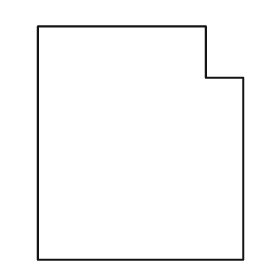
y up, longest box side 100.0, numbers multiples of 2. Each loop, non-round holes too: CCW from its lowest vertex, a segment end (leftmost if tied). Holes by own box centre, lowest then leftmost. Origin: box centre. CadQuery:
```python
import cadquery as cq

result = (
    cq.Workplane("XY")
    .moveTo(-44.0, -50.0)
    .lineTo(44.0, -50.0)
    .lineTo(44.0, 28.0)
    .lineTo(28.0, 28.0)
    .lineTo(28.0, 50.0)
    .lineTo(-44.0, 50.0)
    .close()
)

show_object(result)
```